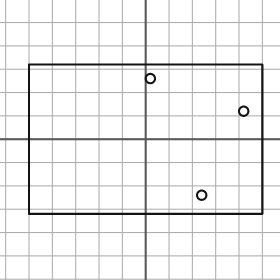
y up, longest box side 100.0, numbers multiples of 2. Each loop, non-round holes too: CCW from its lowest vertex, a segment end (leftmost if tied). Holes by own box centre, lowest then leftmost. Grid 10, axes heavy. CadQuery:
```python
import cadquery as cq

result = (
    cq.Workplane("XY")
    .moveTo(-50.0, -32.0)
    .lineTo(50.0, -32.0)
    .lineTo(50.0, 32.0)
    .lineTo(-50.0, 32.0)
    .close()
    .moveTo(24.0, -24.0)
    .circle(2.0)
    .moveTo(42.0, 12.0)
    .circle(2.0)
    .moveTo(2.0, 26.0)
    .circle(2.0)
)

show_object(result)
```